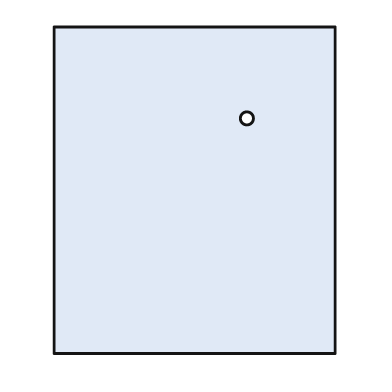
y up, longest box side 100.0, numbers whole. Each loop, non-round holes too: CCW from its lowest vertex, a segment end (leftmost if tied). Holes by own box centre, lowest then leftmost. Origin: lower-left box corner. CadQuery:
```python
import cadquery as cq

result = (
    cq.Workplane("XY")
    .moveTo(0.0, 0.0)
    .lineTo(86.0, 0.0)
    .lineTo(86.0, 100.0)
    .lineTo(0.0, 100.0)
    .close()
    .moveTo(59.0, 72.0)
    .circle(2.0)
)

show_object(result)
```